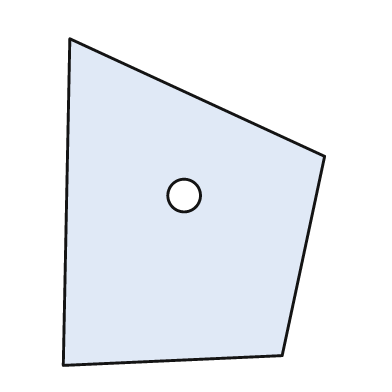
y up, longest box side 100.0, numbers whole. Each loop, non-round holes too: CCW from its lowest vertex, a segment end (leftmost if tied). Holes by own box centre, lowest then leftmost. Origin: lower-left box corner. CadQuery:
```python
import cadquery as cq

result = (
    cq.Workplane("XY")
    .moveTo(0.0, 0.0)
    .lineTo(67.0, 3.0)
    .lineTo(80.0, 64.0)
    .lineTo(2.0, 100.0)
    .close()
    .moveTo(37.0, 52.0)
    .circle(5.0)
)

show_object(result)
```